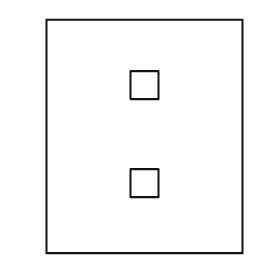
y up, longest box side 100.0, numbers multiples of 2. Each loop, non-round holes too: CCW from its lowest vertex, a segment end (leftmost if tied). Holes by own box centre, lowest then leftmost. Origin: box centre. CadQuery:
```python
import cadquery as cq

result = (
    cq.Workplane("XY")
    .moveTo(-42.0, -50.0)
    .lineTo(42.0, -50.0)
    .lineTo(42.0, 50.0)
    .lineTo(-42.0, 50.0)
    .close()
    .moveTo(-6.0, -26.0)
    .lineTo(6.0, -26.0)
    .lineTo(6.0, -14.0)
    .lineTo(-6.0, -14.0)
    .close()
    .moveTo(-6.0, 16.0)
    .lineTo(6.0, 16.0)
    .lineTo(6.0, 28.0)
    .lineTo(-6.0, 28.0)
    .close()
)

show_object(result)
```